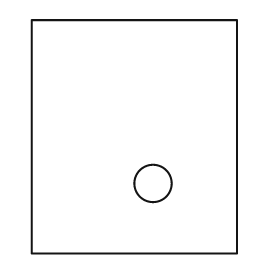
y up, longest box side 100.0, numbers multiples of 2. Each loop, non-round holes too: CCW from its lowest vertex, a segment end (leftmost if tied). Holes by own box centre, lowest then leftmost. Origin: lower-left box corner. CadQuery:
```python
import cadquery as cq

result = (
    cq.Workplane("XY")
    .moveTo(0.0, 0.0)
    .lineTo(88.0, 0.0)
    .lineTo(88.0, 100.0)
    .lineTo(0.0, 100.0)
    .close()
    .moveTo(52.0, 30.0)
    .circle(8.0)
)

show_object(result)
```